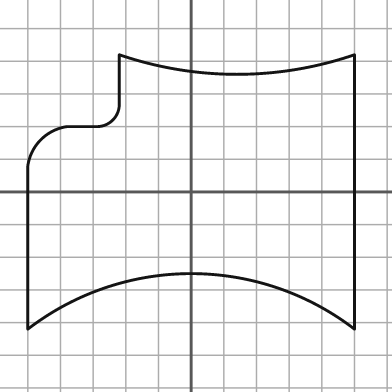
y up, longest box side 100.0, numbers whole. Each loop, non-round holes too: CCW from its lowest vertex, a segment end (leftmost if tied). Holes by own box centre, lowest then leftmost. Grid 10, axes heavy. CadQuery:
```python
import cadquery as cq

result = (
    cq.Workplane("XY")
    .moveTo(-50.0, -42.0)
    .threePointArc((0.0, -25.0), (50.0, -42.0))
    .lineTo(50.0, 42.0)
    .threePointArc((14.0, 36.0), (-22.0, 42.0))
    .lineTo(-22.0, 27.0)
    .threePointArc((-24.0, 22.0), (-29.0, 20.0))
    .lineTo(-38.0, 20.0)
    .threePointArc((-46.0, 16.0), (-50.0, 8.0))
    .close()
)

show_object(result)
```